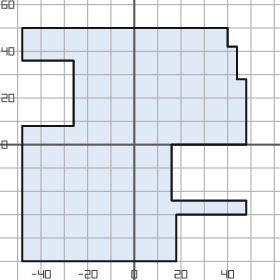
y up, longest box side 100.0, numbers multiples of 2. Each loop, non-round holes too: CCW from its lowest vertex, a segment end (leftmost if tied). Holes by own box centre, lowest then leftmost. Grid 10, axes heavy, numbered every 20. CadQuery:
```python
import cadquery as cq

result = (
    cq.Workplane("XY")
    .moveTo(-48.0, -50.0)
    .lineTo(18.0, -50.0)
    .lineTo(18.0, -30.0)
    .lineTo(48.0, -30.0)
    .lineTo(48.0, -24.0)
    .lineTo(16.0, -24.0)
    .lineTo(16.0, 0.0)
    .lineTo(48.0, 0.0)
    .lineTo(48.0, 28.0)
    .lineTo(44.0, 28.0)
    .lineTo(44.0, 42.0)
    .lineTo(40.0, 42.0)
    .lineTo(40.0, 50.0)
    .lineTo(-48.0, 50.0)
    .lineTo(-48.0, 36.0)
    .lineTo(-26.0, 36.0)
    .lineTo(-26.0, 8.0)
    .lineTo(-48.0, 8.0)
    .close()
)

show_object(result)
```